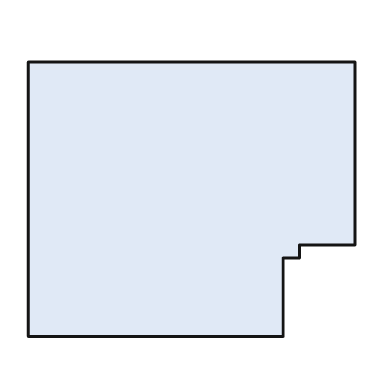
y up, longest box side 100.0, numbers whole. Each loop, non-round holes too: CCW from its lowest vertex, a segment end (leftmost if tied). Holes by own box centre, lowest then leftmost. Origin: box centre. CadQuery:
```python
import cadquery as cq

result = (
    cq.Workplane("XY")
    .moveTo(-50.0, -42.0)
    .lineTo(28.0, -42.0)
    .lineTo(28.0, -18.0)
    .lineTo(33.0, -18.0)
    .lineTo(33.0, -14.0)
    .lineTo(50.0, -14.0)
    .lineTo(50.0, 42.0)
    .lineTo(-50.0, 42.0)
    .close()
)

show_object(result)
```